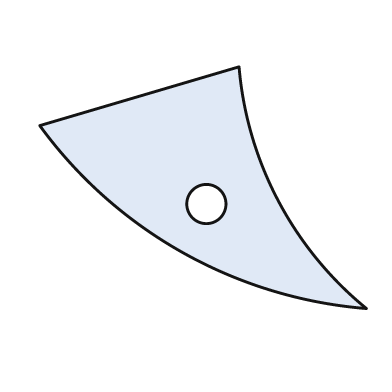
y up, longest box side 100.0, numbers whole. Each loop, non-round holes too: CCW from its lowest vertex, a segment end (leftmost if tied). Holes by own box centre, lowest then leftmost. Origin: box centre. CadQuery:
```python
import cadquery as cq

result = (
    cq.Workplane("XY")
    .moveTo(50.0, -37.0)
    .threePointArc((23.0, -4.0), (11.0, 37.0))
    .lineTo(-50.0, 19.0)
    .threePointArc((-6.0, -20.0), (50.0, -37.0))
    .close()
    .moveTo(1.0, -5.0)
    .circle(6.0)
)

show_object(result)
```